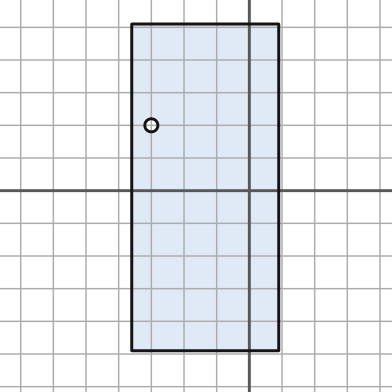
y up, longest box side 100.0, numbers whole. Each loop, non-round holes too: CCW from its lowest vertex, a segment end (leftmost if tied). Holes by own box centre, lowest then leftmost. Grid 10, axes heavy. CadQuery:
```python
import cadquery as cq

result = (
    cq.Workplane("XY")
    .moveTo(-36.0, -49.0)
    .lineTo(9.0, -49.0)
    .lineTo(9.0, 51.0)
    .lineTo(-36.0, 51.0)
    .close()
    .moveTo(-30.0, 20.0)
    .circle(2.0)
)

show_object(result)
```